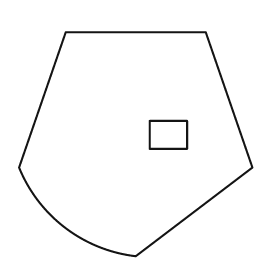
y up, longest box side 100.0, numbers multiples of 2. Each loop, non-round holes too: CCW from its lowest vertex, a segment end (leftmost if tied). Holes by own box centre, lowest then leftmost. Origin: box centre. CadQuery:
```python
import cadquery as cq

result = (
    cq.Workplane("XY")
    .moveTo(0.0, -48.0)
    .lineTo(50.0, -10.0)
    .lineTo(30.0, 48.0)
    .lineTo(-30.0, 48.0)
    .lineTo(-50.0, -10.0)
    .threePointArc((-30.0, -36.0), (0.0, -48.0))
    .close()
    .moveTo(6.0, -2.0)
    .lineTo(22.0, -2.0)
    .lineTo(22.0, 10.0)
    .lineTo(6.0, 10.0)
    .close()
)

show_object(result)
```